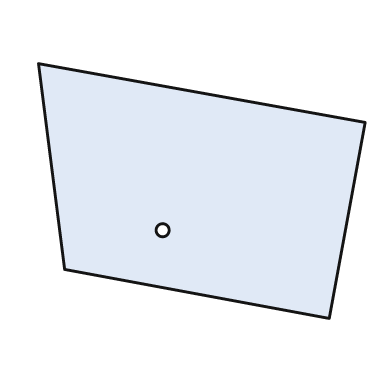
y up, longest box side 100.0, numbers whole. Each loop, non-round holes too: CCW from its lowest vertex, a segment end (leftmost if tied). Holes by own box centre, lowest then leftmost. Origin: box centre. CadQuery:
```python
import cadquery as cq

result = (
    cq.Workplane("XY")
    .moveTo(39.0, -39.0)
    .lineTo(50.0, 21.0)
    .lineTo(-50.0, 39.0)
    .lineTo(-42.0, -24.0)
    .close()
    .moveTo(-12.0, -12.0)
    .circle(2.0)
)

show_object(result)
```